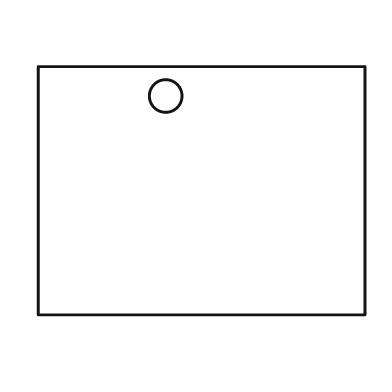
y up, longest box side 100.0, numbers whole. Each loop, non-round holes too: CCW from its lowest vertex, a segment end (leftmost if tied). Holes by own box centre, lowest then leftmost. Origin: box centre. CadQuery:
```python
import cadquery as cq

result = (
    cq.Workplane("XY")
    .moveTo(-50.0, -38.0)
    .lineTo(50.0, -38.0)
    .lineTo(50.0, 38.0)
    .lineTo(-50.0, 38.0)
    .close()
    .moveTo(-11.0, 29.0)
    .circle(5.0)
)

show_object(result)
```